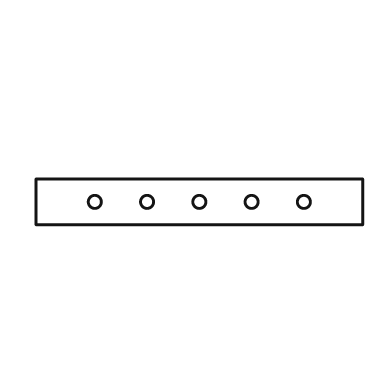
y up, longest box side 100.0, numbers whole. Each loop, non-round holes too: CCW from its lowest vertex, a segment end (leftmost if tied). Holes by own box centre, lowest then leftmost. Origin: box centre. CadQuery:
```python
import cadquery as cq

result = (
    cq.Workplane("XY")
    .moveTo(-50.0, -7.0)
    .lineTo(50.0, -7.0)
    .lineTo(50.0, 7.0)
    .lineTo(-50.0, 7.0)
    .close()
    .moveTo(-32.0, 0.0)
    .circle(2.0)
    .moveTo(-16.0, 0.0)
    .circle(2.0)
    .moveTo(0.0, 0.0)
    .circle(2.0)
    .moveTo(16.0, 0.0)
    .circle(2.0)
    .moveTo(32.0, 0.0)
    .circle(2.0)
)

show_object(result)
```